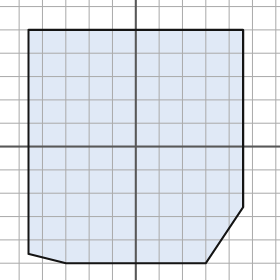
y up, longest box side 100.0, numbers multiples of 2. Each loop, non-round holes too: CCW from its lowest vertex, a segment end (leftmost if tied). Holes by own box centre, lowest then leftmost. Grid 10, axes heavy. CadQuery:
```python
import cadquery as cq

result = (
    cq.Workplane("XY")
    .moveTo(-30.0, -50.0)
    .lineTo(30.0, -50.0)
    .lineTo(46.0, -26.0)
    .lineTo(46.0, 50.0)
    .lineTo(-46.0, 50.0)
    .lineTo(-46.0, -46.0)
    .close()
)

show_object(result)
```